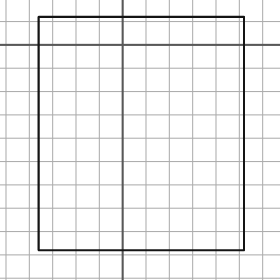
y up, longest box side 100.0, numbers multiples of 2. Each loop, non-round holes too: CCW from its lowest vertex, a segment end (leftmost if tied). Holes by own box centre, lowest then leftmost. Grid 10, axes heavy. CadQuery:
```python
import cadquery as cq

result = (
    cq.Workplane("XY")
    .moveTo(-36.0, -88.0)
    .lineTo(52.0, -88.0)
    .lineTo(52.0, 12.0)
    .lineTo(-36.0, 12.0)
    .close()
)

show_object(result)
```